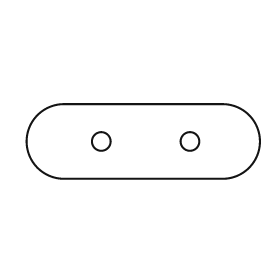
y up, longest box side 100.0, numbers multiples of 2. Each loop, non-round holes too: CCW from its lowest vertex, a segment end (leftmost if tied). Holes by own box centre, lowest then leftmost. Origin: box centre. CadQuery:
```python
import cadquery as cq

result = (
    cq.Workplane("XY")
    .moveTo(-34.0, -16.0)
    .lineTo(34.0, -16.0)
    .threePointArc((50.0, 0.0), (34.0, 16.0))
    .lineTo(-34.0, 16.0)
    .threePointArc((-50.0, 0.0), (-34.0, -16.0))
    .close()
    .moveTo(-18.0, 0.0)
    .circle(4.0)
    .moveTo(20.0, 0.0)
    .circle(4.0)
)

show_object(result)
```